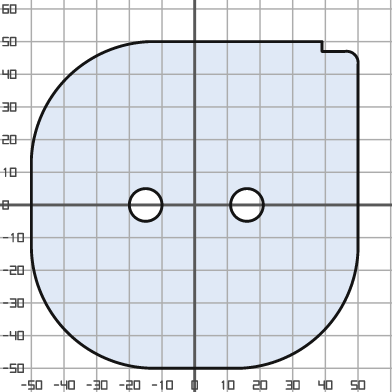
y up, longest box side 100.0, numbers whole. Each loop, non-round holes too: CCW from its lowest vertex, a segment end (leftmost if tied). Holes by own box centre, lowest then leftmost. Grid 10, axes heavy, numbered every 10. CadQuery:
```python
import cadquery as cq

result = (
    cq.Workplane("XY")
    .moveTo(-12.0, -50.0)
    .lineTo(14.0, -50.0)
    .threePointArc((39.0, -39.0), (50.0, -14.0))
    .lineTo(50.0, 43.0)
    .threePointArc((49.0, 46.0), (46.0, 47.0))
    .lineTo(39.0, 47.0)
    .lineTo(39.0, 50.0)
    .lineTo(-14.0, 50.0)
    .threePointArc((-39.0, 39.0), (-50.0, 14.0))
    .lineTo(-50.0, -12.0)
    .threePointArc((-39.0, -39.0), (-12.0, -50.0))
    .close()
    .moveTo(-15.0, 0.0)
    .circle(5.0)
    .moveTo(16.0, 0.0)
    .circle(5.0)
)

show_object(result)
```